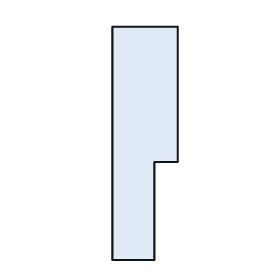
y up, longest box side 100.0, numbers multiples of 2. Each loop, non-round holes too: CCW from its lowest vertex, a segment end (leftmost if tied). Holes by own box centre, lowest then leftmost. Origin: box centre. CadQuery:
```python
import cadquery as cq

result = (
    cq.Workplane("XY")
    .moveTo(-14.0, -50.0)
    .lineTo(4.0, -50.0)
    .lineTo(4.0, -8.0)
    .lineTo(14.0, -8.0)
    .lineTo(14.0, 50.0)
    .lineTo(-14.0, 50.0)
    .close()
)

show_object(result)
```